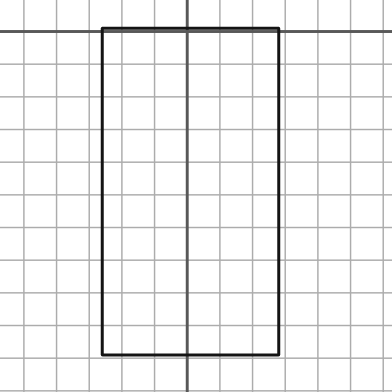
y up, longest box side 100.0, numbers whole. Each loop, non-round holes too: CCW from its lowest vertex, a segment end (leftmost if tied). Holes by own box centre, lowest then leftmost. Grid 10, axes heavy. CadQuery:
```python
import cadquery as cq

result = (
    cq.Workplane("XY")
    .moveTo(-26.0, -99.0)
    .lineTo(28.0, -99.0)
    .lineTo(28.0, 1.0)
    .lineTo(-26.0, 1.0)
    .close()
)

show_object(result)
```